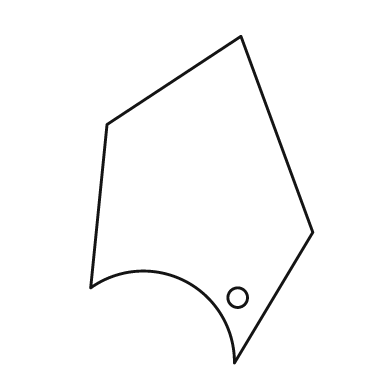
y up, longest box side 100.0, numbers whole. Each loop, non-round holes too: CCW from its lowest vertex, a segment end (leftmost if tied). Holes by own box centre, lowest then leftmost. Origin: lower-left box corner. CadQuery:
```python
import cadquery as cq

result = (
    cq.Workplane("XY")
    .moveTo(44.0, 0.0)
    .lineTo(68.0, 40.0)
    .lineTo(46.0, 100.0)
    .lineTo(5.0, 73.0)
    .lineTo(0.0, 23.0)
    .threePointArc((29.0, 25.0), (44.0, 0.0))
    .close()
    .moveTo(45.0, 20.0)
    .circle(3.0)
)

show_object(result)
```